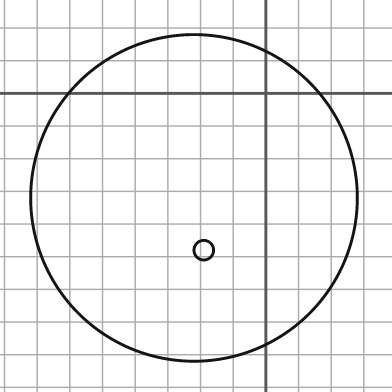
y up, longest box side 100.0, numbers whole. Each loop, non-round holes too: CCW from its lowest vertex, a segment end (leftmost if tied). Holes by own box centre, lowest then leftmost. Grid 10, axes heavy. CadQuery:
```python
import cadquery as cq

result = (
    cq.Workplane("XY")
    .moveTo(-22.0, -32.0)
    .circle(50.0)
    .moveTo(-19.0, -48.0)
    .circle(3.0)
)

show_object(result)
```